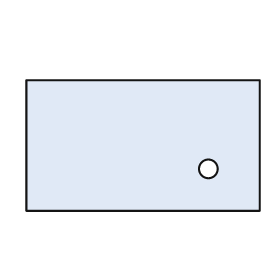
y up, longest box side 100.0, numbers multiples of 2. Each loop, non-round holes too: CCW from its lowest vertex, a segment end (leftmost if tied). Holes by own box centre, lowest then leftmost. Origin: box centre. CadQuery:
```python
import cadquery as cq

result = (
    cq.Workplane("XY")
    .moveTo(-50.0, -28.0)
    .lineTo(50.0, -28.0)
    .lineTo(50.0, 28.0)
    .lineTo(-50.0, 28.0)
    .close()
    .moveTo(28.0, -10.0)
    .circle(4.0)
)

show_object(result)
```